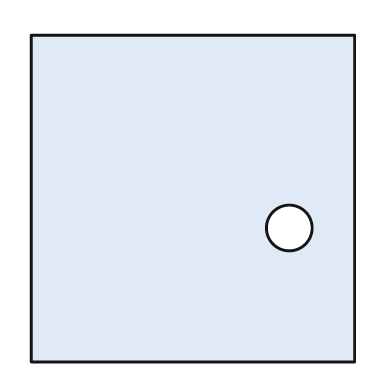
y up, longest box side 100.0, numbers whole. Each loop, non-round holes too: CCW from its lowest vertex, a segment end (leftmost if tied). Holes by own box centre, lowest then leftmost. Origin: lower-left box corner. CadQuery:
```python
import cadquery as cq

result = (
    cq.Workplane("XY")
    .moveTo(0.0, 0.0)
    .lineTo(99.0, 0.0)
    .lineTo(99.0, 100.0)
    .lineTo(0.0, 100.0)
    .close()
    .moveTo(79.0, 41.0)
    .circle(7.0)
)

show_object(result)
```